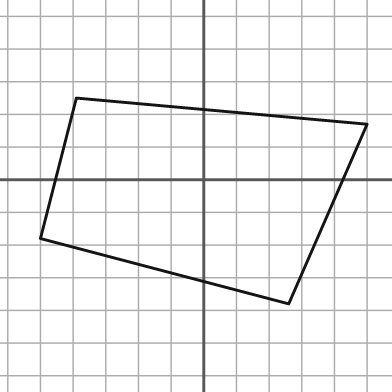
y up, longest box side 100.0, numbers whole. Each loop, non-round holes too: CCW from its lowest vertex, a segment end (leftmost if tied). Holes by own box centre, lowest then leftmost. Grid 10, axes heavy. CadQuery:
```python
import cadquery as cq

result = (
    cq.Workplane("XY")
    .moveTo(26.0, -38.0)
    .lineTo(50.0, 17.0)
    .lineTo(-39.0, 25.0)
    .lineTo(-50.0, -18.0)
    .close()
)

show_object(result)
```